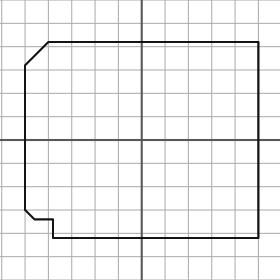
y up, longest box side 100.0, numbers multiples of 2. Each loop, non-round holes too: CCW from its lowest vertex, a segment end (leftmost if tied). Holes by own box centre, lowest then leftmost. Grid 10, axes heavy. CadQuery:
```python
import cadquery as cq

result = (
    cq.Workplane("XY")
    .moveTo(-38.0, -42.0)
    .lineTo(50.0, -42.0)
    .lineTo(50.0, 42.0)
    .lineTo(-40.0, 42.0)
    .lineTo(-50.0, 32.0)
    .lineTo(-50.0, -30.0)
    .lineTo(-46.0, -34.0)
    .lineTo(-38.0, -34.0)
    .close()
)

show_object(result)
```